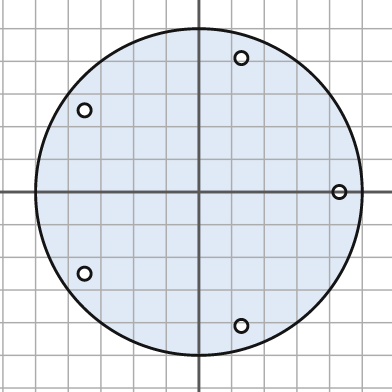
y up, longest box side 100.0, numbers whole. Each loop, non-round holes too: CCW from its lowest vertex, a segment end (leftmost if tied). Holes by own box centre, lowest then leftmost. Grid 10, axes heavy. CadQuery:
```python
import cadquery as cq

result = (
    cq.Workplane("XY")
    .moveTo(0.0, 0.0)
    .circle(50.0)
    .moveTo(13.0, -41.0)
    .circle(2.0)
    .moveTo(-35.0, -25.0)
    .circle(2.0)
    .moveTo(43.0, 0.0)
    .circle(2.0)
    .moveTo(-35.0, 25.0)
    .circle(2.0)
    .moveTo(13.0, 41.0)
    .circle(2.0)
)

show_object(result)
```